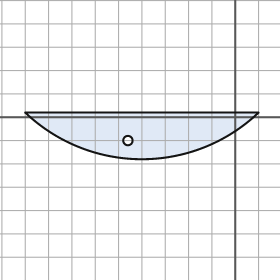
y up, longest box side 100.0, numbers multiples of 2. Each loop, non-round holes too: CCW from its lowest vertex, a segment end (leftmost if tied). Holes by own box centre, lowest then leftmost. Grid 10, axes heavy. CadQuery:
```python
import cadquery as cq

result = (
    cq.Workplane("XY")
    .moveTo(-90.0, 2.0)
    .threePointArc((-40.0, -18.0), (10.0, 2.0))
    .close()
    .moveTo(-46.0, -10.0)
    .circle(2.0)
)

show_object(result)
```